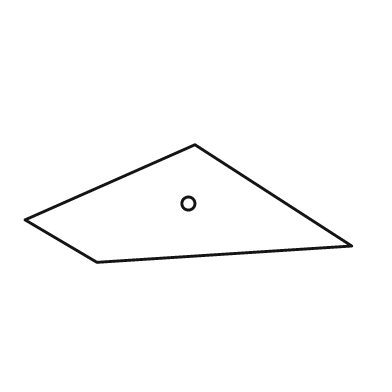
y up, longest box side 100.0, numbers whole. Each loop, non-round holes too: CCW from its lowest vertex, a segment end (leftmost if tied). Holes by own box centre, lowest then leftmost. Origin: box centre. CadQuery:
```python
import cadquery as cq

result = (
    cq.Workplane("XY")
    .moveTo(-28.0, -18.0)
    .lineTo(50.0, -13.0)
    .lineTo(2.0, 18.0)
    .lineTo(-50.0, -5.0)
    .close()
    .moveTo(0.0, 0.0)
    .circle(2.0)
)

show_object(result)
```